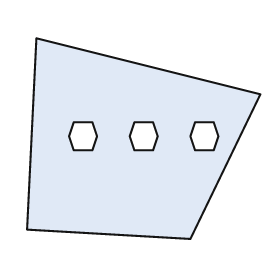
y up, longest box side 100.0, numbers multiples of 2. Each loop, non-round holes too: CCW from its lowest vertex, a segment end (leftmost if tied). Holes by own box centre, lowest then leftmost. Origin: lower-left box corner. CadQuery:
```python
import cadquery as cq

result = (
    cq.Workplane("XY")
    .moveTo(70.0, 0.0)
    .lineTo(100.0, 62.0)
    .lineTo(4.0, 86.0)
    .lineTo(0.0, 4.0)
    .close()
    .moveTo(20.0, 38.0)
    .lineTo(28.0, 38.0)
    .lineTo(30.0, 44.0)
    .lineTo(28.0, 50.0)
    .lineTo(20.0, 50.0)
    .lineTo(18.0, 44.0)
    .close()
    .moveTo(46.0, 38.0)
    .lineTo(54.0, 38.0)
    .lineTo(56.0, 44.0)
    .lineTo(54.0, 50.0)
    .lineTo(46.0, 50.0)
    .lineTo(44.0, 44.0)
    .close()
    .moveTo(72.0, 38.0)
    .lineTo(80.0, 38.0)
    .lineTo(82.0, 44.0)
    .lineTo(80.0, 50.0)
    .lineTo(72.0, 50.0)
    .lineTo(70.0, 44.0)
    .close()
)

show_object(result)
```